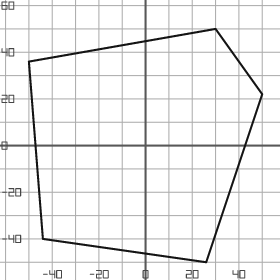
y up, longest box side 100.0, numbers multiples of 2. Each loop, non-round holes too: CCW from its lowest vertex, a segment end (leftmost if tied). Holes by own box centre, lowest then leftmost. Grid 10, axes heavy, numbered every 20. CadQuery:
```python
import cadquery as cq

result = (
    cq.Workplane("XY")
    .moveTo(26.0, -50.0)
    .lineTo(50.0, 22.0)
    .lineTo(30.0, 50.0)
    .lineTo(-50.0, 36.0)
    .lineTo(-44.0, -40.0)
    .close()
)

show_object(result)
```